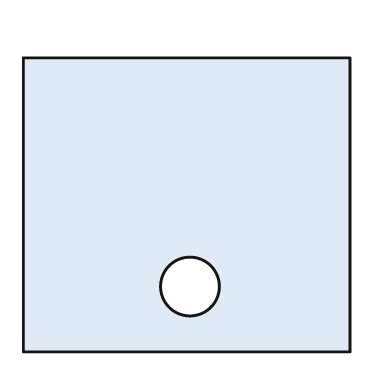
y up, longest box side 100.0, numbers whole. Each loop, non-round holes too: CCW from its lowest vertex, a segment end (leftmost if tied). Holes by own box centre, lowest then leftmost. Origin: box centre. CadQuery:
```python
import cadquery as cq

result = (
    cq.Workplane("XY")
    .moveTo(-50.0, -45.0)
    .lineTo(50.0, -45.0)
    .lineTo(50.0, 45.0)
    .lineTo(-50.0, 45.0)
    .close()
    .moveTo(1.0, -25.0)
    .circle(9.0)
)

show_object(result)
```